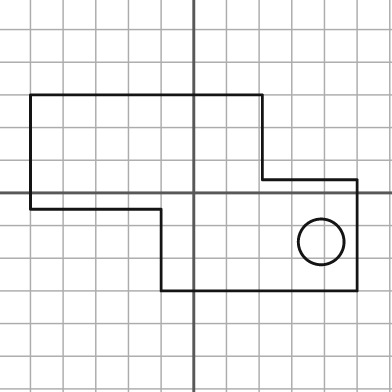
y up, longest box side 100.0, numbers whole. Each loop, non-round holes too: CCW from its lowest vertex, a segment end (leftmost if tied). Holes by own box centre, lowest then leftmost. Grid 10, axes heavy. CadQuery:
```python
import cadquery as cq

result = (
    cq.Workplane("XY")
    .moveTo(-10.0, -30.0)
    .lineTo(50.0, -30.0)
    .lineTo(50.0, 4.0)
    .lineTo(21.0, 4.0)
    .lineTo(21.0, 30.0)
    .lineTo(-50.0, 30.0)
    .lineTo(-50.0, -5.0)
    .lineTo(-10.0, -5.0)
    .close()
    .moveTo(39.0, -15.0)
    .circle(7.0)
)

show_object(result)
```